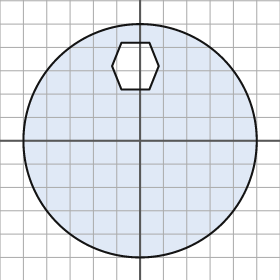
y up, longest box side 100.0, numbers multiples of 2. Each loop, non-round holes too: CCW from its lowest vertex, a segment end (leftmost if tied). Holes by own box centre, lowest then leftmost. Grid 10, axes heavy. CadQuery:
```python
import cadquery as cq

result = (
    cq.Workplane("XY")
    .moveTo(0.0, 0.0)
    .circle(50.0)
    .moveTo(-8.0, 22.0)
    .lineTo(4.0, 22.0)
    .lineTo(8.0, 32.0)
    .lineTo(4.0, 42.0)
    .lineTo(-8.0, 42.0)
    .lineTo(-12.0, 32.0)
    .close()
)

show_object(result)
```